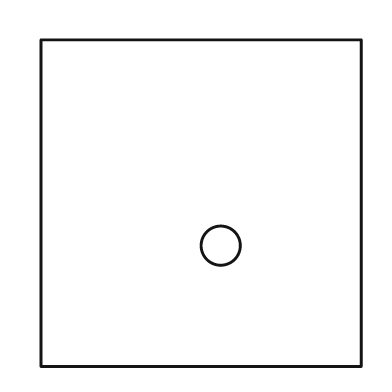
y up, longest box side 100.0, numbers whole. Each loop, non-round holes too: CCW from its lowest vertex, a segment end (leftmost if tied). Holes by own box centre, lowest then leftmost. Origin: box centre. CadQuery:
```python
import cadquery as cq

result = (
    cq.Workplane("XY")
    .moveTo(-49.0, -50.0)
    .lineTo(49.0, -50.0)
    .lineTo(49.0, 50.0)
    .lineTo(-49.0, 50.0)
    .close()
    .moveTo(6.0, -13.0)
    .circle(6.0)
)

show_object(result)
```